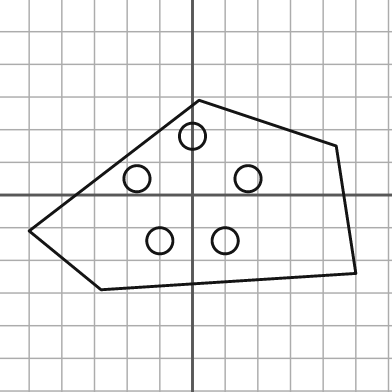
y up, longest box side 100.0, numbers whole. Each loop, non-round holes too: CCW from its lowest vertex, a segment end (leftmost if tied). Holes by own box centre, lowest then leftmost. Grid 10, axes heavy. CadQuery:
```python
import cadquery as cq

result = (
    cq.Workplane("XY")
    .moveTo(-28.0, -29.0)
    .lineTo(50.0, -24.0)
    .lineTo(44.0, 15.0)
    .lineTo(2.0, 29.0)
    .lineTo(-50.0, -11.0)
    .close()
    .moveTo(-10.0, -14.0)
    .circle(4.0)
    .moveTo(10.0, -14.0)
    .circle(4.0)
    .moveTo(-17.0, 5.0)
    .circle(4.0)
    .moveTo(17.0, 5.0)
    .circle(4.0)
    .moveTo(0.0, 18.0)
    .circle(4.0)
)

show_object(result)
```